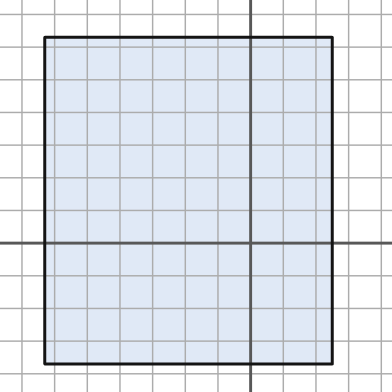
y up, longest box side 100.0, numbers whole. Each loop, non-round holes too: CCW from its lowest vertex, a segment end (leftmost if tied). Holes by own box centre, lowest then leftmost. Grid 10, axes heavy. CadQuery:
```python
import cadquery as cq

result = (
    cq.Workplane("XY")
    .moveTo(-63.0, -37.0)
    .lineTo(25.0, -37.0)
    .lineTo(25.0, 63.0)
    .lineTo(-63.0, 63.0)
    .close()
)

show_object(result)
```